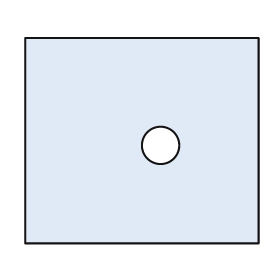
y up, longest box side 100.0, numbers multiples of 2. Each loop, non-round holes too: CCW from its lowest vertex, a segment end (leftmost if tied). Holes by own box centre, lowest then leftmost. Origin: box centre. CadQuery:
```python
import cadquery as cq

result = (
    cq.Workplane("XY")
    .moveTo(-50.0, -44.0)
    .lineTo(50.0, -44.0)
    .lineTo(50.0, 44.0)
    .lineTo(-50.0, 44.0)
    .close()
    .moveTo(8.0, -2.0)
    .circle(8.0)
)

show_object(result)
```